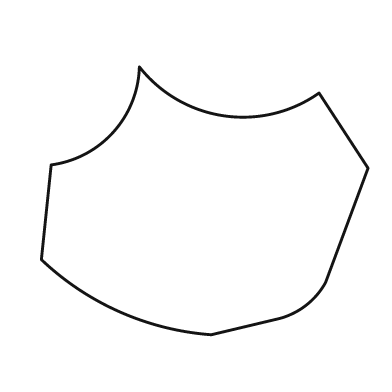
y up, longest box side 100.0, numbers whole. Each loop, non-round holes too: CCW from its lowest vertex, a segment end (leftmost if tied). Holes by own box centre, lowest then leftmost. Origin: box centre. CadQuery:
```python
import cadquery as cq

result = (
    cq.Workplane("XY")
    .moveTo(2.0, -41.0)
    .lineTo(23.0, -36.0)
    .threePointArc((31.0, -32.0), (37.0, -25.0))
    .lineTo(50.0, 10.0)
    .lineTo(35.0, 33.0)
    .threePointArc((6.0, 26.0), (-20.0, 41.0))
    .threePointArc((-28.0, 21.0), (-47.0, 11.0))
    .lineTo(-50.0, -18.0)
    .threePointArc((-26.0, -34.0), (2.0, -41.0))
    .close()
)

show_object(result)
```